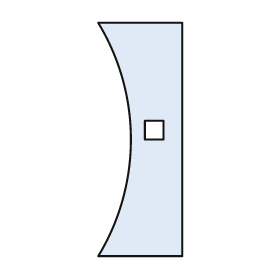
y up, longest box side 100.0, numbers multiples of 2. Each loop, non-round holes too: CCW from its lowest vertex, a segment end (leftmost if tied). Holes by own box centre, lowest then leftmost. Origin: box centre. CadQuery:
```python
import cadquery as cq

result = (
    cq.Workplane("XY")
    .moveTo(-18.0, -50.0)
    .lineTo(18.0, -50.0)
    .lineTo(18.0, 50.0)
    .lineTo(-18.0, 50.0)
    .threePointArc((-4.0, 0.0), (-18.0, -50.0))
    .close()
    .moveTo(2.0, 0.0)
    .lineTo(10.0, 0.0)
    .lineTo(10.0, 8.0)
    .lineTo(2.0, 8.0)
    .close()
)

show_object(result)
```